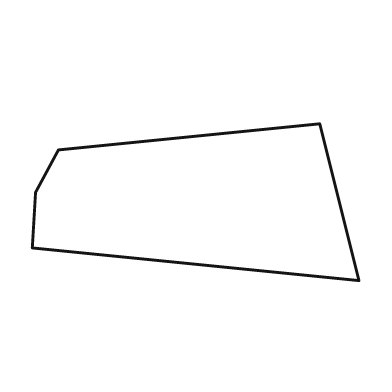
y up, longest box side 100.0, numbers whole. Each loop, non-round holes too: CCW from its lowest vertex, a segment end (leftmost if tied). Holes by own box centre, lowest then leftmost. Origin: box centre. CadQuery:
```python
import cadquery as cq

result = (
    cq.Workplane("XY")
    .moveTo(50.0, -24.0)
    .lineTo(38.0, 24.0)
    .lineTo(-42.0, 16.0)
    .lineTo(-49.0, 3.0)
    .lineTo(-50.0, -14.0)
    .close()
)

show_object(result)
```